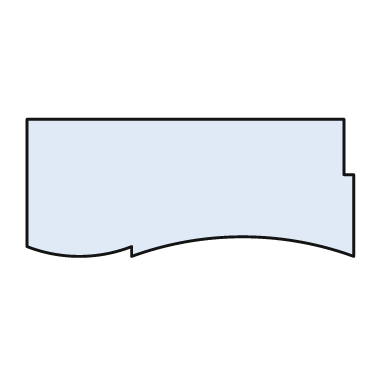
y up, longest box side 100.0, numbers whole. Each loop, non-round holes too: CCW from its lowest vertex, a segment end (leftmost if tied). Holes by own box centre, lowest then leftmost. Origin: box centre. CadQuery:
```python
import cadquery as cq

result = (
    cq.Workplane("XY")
    .moveTo(-18.0, -21.0)
    .threePointArc((16.0, -15.0), (50.0, -21.0))
    .lineTo(50.0, 4.0)
    .lineTo(47.0, 4.0)
    .lineTo(47.0, 21.0)
    .lineTo(-50.0, 21.0)
    .lineTo(-50.0, -18.0)
    .threePointArc((-34.0, -21.0), (-18.0, -18.0))
    .close()
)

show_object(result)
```